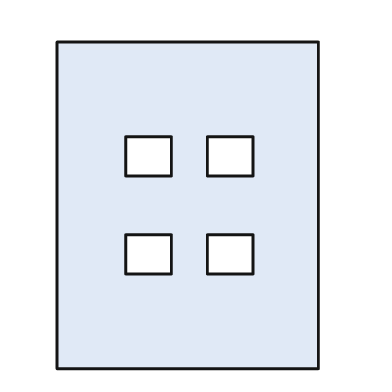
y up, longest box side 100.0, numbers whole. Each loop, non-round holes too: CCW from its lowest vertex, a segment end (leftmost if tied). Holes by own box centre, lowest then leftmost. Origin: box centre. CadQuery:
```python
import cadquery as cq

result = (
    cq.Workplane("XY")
    .moveTo(-40.0, -50.0)
    .lineTo(40.0, -50.0)
    .lineTo(40.0, 50.0)
    .lineTo(-40.0, 50.0)
    .close()
    .moveTo(-19.0, -21.0)
    .lineTo(-5.0, -21.0)
    .lineTo(-5.0, -9.0)
    .lineTo(-19.0, -9.0)
    .close()
    .moveTo(6.0, -21.0)
    .lineTo(20.0, -21.0)
    .lineTo(20.0, -9.0)
    .lineTo(6.0, -9.0)
    .close()
    .moveTo(-19.0, 9.0)
    .lineTo(-5.0, 9.0)
    .lineTo(-5.0, 21.0)
    .lineTo(-19.0, 21.0)
    .close()
    .moveTo(6.0, 9.0)
    .lineTo(20.0, 9.0)
    .lineTo(20.0, 21.0)
    .lineTo(6.0, 21.0)
    .close()
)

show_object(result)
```